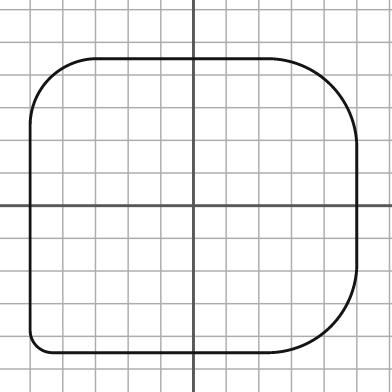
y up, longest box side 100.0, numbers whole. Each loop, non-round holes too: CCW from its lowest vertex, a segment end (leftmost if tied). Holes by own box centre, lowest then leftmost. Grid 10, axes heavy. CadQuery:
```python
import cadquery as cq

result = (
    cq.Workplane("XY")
    .moveTo(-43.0, -45.0)
    .lineTo(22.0, -45.0)
    .threePointArc((42.0, -37.0), (50.0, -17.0))
    .lineTo(50.0, 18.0)
    .threePointArc((42.0, 37.0), (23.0, 45.0))
    .lineTo(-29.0, 45.0)
    .threePointArc((-44.0, 39.0), (-50.0, 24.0))
    .lineTo(-50.0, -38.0)
    .threePointArc((-48.0, -43.0), (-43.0, -45.0))
    .close()
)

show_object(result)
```